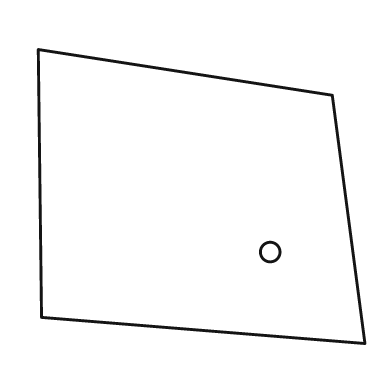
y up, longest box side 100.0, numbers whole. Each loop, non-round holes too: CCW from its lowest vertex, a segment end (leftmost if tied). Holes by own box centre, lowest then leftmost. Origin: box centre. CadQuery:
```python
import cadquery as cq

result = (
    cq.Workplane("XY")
    .moveTo(50.0, -45.0)
    .lineTo(40.0, 31.0)
    .lineTo(-50.0, 45.0)
    .lineTo(-49.0, -37.0)
    .close()
    .moveTo(21.0, -17.0)
    .circle(3.0)
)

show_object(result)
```